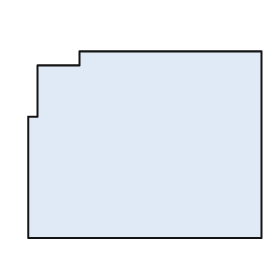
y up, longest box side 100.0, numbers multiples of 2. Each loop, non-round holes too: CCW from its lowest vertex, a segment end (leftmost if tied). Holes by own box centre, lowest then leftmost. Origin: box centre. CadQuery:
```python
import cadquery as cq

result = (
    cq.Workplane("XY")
    .moveTo(-50.0, -40.0)
    .lineTo(50.0, -40.0)
    .lineTo(50.0, 40.0)
    .lineTo(-28.0, 40.0)
    .lineTo(-28.0, 34.0)
    .lineTo(-46.0, 34.0)
    .lineTo(-46.0, 12.0)
    .lineTo(-50.0, 12.0)
    .close()
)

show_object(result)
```